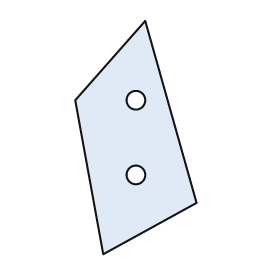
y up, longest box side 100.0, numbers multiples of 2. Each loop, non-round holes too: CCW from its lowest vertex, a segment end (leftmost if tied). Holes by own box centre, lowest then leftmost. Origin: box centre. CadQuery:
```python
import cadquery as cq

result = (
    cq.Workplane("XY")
    .moveTo(-14.0, -50.0)
    .lineTo(26.0, -28.0)
    .lineTo(4.0, 50.0)
    .lineTo(-26.0, 16.0)
    .close()
    .moveTo(0.0, -16.0)
    .circle(4.0)
    .moveTo(0.0, 16.0)
    .circle(4.0)
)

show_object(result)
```